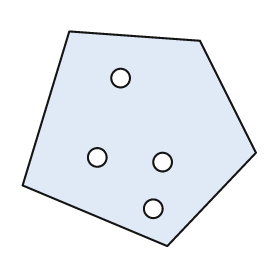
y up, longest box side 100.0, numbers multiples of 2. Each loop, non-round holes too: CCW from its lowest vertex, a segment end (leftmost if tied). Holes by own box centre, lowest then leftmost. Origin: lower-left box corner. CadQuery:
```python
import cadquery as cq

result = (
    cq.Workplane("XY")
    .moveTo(62.0, 0.0)
    .lineTo(100.0, 40.0)
    .lineTo(76.0, 88.0)
    .lineTo(20.0, 92.0)
    .lineTo(0.0, 26.0)
    .close()
    .moveTo(56.0, 16.0)
    .circle(4.0)
    .moveTo(60.0, 36.0)
    .circle(4.0)
    .moveTo(32.0, 38.0)
    .circle(4.0)
    .moveTo(42.0, 72.0)
    .circle(4.0)
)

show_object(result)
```